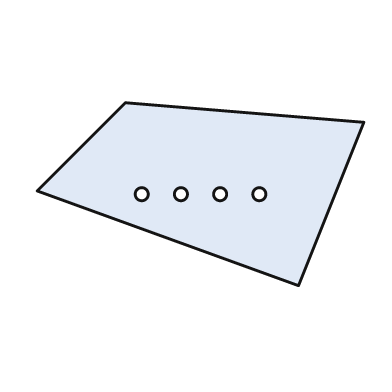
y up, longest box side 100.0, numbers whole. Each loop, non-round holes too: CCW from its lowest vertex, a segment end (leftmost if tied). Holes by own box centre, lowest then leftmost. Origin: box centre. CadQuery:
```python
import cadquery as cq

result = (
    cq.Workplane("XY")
    .moveTo(30.0, -28.0)
    .lineTo(50.0, 22.0)
    .lineTo(-23.0, 28.0)
    .lineTo(-50.0, 1.0)
    .close()
    .moveTo(-18.0, 0.0)
    .circle(2.0)
    .moveTo(-6.0, 0.0)
    .circle(2.0)
    .moveTo(6.0, 0.0)
    .circle(2.0)
    .moveTo(18.0, 0.0)
    .circle(2.0)
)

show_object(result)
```